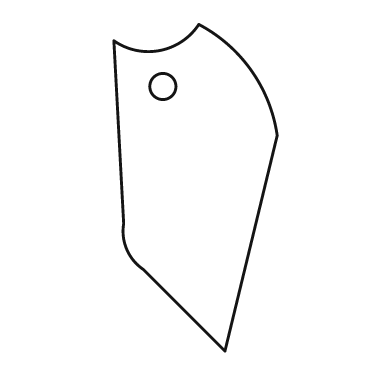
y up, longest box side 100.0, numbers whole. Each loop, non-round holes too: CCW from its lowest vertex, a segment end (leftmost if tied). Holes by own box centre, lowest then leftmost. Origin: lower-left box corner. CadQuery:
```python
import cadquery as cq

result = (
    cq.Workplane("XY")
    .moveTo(34.0, 0.0)
    .lineTo(50.0, 66.0)
    .threePointArc((42.0, 86.0), (26.0, 100.0))
    .threePointArc((14.0, 92.0), (0.0, 95.0))
    .lineTo(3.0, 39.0)
    .threePointArc((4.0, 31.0), (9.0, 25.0))
    .close()
    .moveTo(15.0, 81.0)
    .circle(4.0)
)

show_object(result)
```